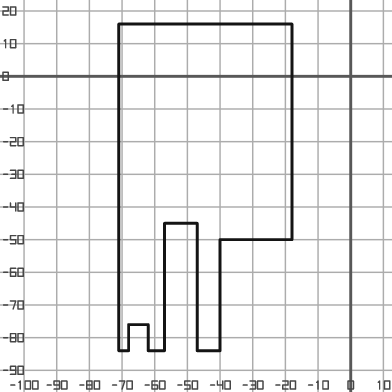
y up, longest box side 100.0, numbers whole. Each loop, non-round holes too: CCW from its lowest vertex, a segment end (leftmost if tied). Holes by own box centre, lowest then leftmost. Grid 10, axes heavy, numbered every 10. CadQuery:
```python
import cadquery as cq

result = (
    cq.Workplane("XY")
    .moveTo(-71.0, -84.0)
    .lineTo(-68.0, -84.0)
    .lineTo(-68.0, -76.0)
    .lineTo(-62.0, -76.0)
    .lineTo(-62.0, -84.0)
    .lineTo(-57.0, -84.0)
    .lineTo(-57.0, -45.0)
    .lineTo(-47.0, -45.0)
    .lineTo(-47.0, -84.0)
    .lineTo(-40.0, -84.0)
    .lineTo(-40.0, -50.0)
    .lineTo(-18.0, -50.0)
    .lineTo(-18.0, 16.0)
    .lineTo(-71.0, 16.0)
    .close()
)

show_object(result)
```